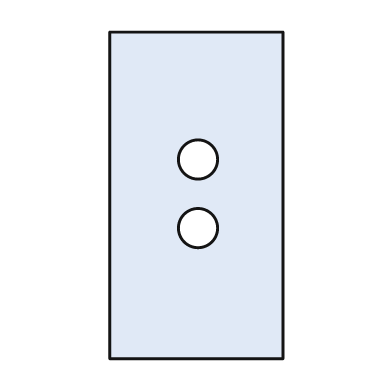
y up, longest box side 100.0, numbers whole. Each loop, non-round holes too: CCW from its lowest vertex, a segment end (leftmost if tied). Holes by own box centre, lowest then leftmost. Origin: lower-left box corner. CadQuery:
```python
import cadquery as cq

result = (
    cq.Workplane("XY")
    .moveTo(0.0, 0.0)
    .lineTo(53.0, 0.0)
    .lineTo(53.0, 100.0)
    .lineTo(0.0, 100.0)
    .close()
    .moveTo(27.0, 40.0)
    .circle(6.0)
    .moveTo(27.0, 61.0)
    .circle(6.0)
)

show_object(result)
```